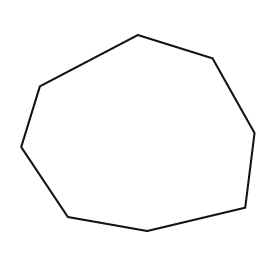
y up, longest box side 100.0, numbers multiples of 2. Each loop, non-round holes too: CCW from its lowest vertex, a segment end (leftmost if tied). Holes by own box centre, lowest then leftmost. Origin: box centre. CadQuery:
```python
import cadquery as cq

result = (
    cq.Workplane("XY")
    .moveTo(4.0, -42.0)
    .lineTo(46.0, -32.0)
    .lineTo(50.0, 0.0)
    .lineTo(32.0, 32.0)
    .lineTo(0.0, 42.0)
    .lineTo(-42.0, 20.0)
    .lineTo(-50.0, -6.0)
    .lineTo(-30.0, -36.0)
    .close()
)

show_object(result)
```